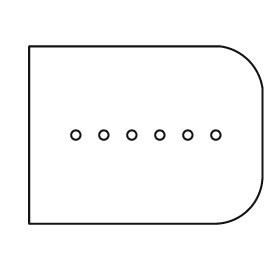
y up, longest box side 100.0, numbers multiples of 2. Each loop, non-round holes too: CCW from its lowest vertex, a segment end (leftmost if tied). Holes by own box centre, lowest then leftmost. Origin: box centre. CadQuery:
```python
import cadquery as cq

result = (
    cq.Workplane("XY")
    .moveTo(-50.0, -38.0)
    .lineTo(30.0, -38.0)
    .threePointArc((44.0, -32.0), (50.0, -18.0))
    .lineTo(50.0, 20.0)
    .threePointArc((44.0, 32.0), (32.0, 38.0))
    .lineTo(-50.0, 38.0)
    .close()
    .moveTo(-30.0, 0.0)
    .circle(2.0)
    .moveTo(-18.0, 0.0)
    .circle(2.0)
    .moveTo(-6.0, 0.0)
    .circle(2.0)
    .moveTo(6.0, 0.0)
    .circle(2.0)
    .moveTo(18.0, 0.0)
    .circle(2.0)
    .moveTo(30.0, 0.0)
    .circle(2.0)
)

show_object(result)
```